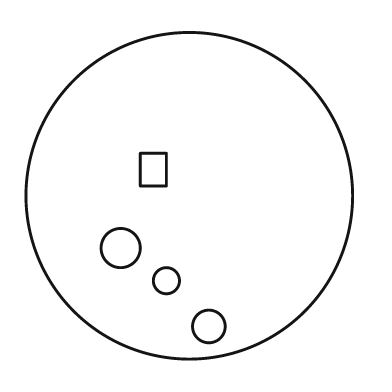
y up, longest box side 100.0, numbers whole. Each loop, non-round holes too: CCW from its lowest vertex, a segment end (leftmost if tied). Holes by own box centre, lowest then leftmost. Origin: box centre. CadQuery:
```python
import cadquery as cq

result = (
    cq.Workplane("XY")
    .moveTo(0.0, 0.0)
    .circle(50.0)
    .moveTo(6.0, -40.0)
    .circle(5.0)
    .moveTo(-7.0, -26.0)
    .circle(4.0)
    .moveTo(-21.0, -16.0)
    .circle(6.0)
    .moveTo(-15.0, 3.0)
    .lineTo(-7.0, 3.0)
    .lineTo(-7.0, 13.0)
    .lineTo(-15.0, 13.0)
    .close()
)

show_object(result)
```